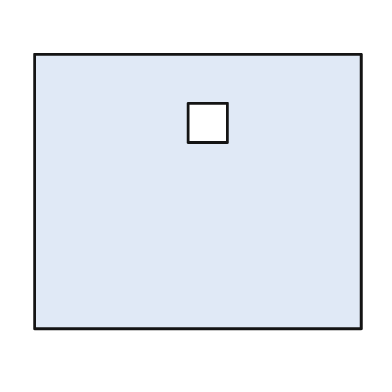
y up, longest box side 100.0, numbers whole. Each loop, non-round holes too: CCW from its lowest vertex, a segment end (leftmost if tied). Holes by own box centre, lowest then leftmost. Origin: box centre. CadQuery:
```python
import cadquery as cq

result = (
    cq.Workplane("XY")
    .moveTo(-50.0, -42.0)
    .lineTo(50.0, -42.0)
    .lineTo(50.0, 42.0)
    .lineTo(-50.0, 42.0)
    .close()
    .moveTo(-3.0, 15.0)
    .lineTo(9.0, 15.0)
    .lineTo(9.0, 27.0)
    .lineTo(-3.0, 27.0)
    .close()
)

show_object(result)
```